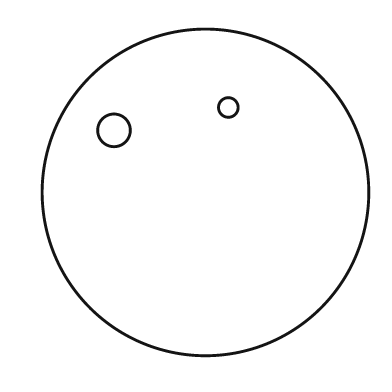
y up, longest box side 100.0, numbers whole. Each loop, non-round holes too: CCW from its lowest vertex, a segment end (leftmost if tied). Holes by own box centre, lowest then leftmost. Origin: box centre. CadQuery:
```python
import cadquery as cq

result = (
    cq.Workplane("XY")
    .moveTo(0.0, 0.0)
    .circle(50.0)
    .moveTo(-28.0, 19.0)
    .circle(5.0)
    .moveTo(7.0, 26.0)
    .circle(3.0)
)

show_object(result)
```